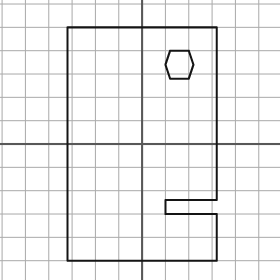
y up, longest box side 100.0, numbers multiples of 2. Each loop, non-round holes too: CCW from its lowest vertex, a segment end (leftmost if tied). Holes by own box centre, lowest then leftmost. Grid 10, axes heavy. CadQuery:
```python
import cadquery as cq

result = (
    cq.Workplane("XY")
    .moveTo(-32.0, -50.0)
    .lineTo(32.0, -50.0)
    .lineTo(32.0, -30.0)
    .lineTo(10.0, -30.0)
    .lineTo(10.0, -24.0)
    .lineTo(32.0, -24.0)
    .lineTo(32.0, 50.0)
    .lineTo(-32.0, 50.0)
    .close()
    .moveTo(12.0, 28.0)
    .lineTo(20.0, 28.0)
    .lineTo(22.0, 34.0)
    .lineTo(20.0, 40.0)
    .lineTo(12.0, 40.0)
    .lineTo(10.0, 34.0)
    .close()
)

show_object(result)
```